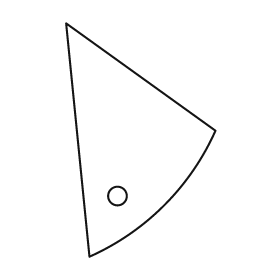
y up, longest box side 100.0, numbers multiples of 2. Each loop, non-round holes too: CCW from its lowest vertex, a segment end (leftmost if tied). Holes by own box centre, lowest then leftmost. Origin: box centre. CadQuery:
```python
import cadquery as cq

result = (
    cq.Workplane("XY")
    .moveTo(-22.0, -50.0)
    .threePointArc((10.0, -28.0), (32.0, 4.0))
    .lineTo(-32.0, 50.0)
    .close()
    .moveTo(-10.0, -24.0)
    .circle(4.0)
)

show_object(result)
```